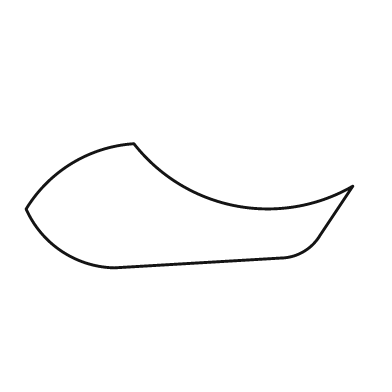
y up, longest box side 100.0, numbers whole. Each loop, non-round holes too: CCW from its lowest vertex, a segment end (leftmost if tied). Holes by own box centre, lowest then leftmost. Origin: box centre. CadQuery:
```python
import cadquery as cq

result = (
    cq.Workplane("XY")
    .moveTo(-23.0, -19.0)
    .lineTo(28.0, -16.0)
    .threePointArc((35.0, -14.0), (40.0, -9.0))
    .lineTo(50.0, 6.0)
    .threePointArc((14.0, 0.0), (-17.0, 19.0))
    .threePointArc((-36.0, 13.0), (-50.0, -1.0))
    .threePointArc((-39.0, -14.0), (-23.0, -19.0))
    .close()
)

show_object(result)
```